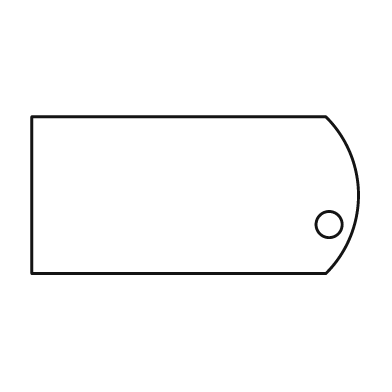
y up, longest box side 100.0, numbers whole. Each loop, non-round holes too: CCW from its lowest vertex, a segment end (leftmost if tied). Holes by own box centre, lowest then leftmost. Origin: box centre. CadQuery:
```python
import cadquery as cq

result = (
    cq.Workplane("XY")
    .moveTo(-50.0, -24.0)
    .lineTo(40.0, -24.0)
    .threePointArc((50.0, 0.0), (40.0, 24.0))
    .lineTo(-50.0, 24.0)
    .close()
    .moveTo(41.0, -9.0)
    .circle(4.0)
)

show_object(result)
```